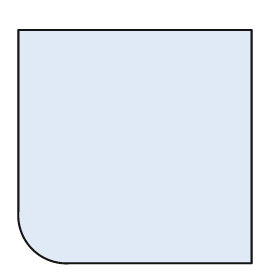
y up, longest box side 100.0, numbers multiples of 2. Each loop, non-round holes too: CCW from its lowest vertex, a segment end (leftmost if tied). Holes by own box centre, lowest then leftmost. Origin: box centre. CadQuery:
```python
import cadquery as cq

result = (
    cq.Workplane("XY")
    .moveTo(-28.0, -50.0)
    .lineTo(50.0, -50.0)
    .lineTo(50.0, 50.0)
    .lineTo(-50.0, 50.0)
    .lineTo(-50.0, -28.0)
    .threePointArc((-44.0, -44.0), (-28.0, -50.0))
    .close()
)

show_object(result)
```